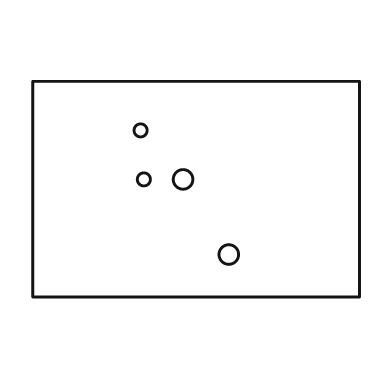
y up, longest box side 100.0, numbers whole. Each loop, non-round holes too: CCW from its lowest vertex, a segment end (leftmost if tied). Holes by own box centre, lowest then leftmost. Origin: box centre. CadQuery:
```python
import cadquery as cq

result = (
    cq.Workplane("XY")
    .moveTo(-50.0, -33.0)
    .lineTo(50.0, -33.0)
    .lineTo(50.0, 33.0)
    .lineTo(-50.0, 33.0)
    .close()
    .moveTo(10.0, -20.0)
    .circle(3.0)
    .moveTo(-16.0, 3.0)
    .circle(2.0)
    .moveTo(-4.0, 3.0)
    .circle(3.0)
    .moveTo(-17.0, 18.0)
    .circle(2.0)
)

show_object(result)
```